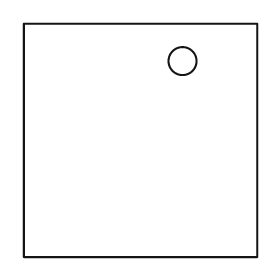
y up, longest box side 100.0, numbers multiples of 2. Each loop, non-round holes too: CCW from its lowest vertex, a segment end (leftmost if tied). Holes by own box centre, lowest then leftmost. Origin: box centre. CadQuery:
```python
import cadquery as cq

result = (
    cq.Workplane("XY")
    .moveTo(-50.0, -50.0)
    .lineTo(50.0, -50.0)
    .lineTo(50.0, 50.0)
    .lineTo(-50.0, 50.0)
    .close()
    .moveTo(18.0, 34.0)
    .circle(6.0)
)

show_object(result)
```